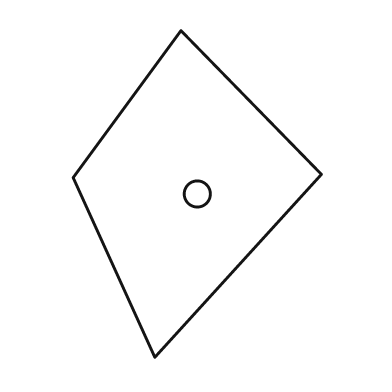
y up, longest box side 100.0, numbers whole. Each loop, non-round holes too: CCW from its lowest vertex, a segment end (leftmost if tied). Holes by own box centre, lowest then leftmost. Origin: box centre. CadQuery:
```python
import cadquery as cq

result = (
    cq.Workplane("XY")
    .moveTo(-13.0, -50.0)
    .lineTo(38.0, 6.0)
    .lineTo(-5.0, 50.0)
    .lineTo(-38.0, 5.0)
    .close()
    .moveTo(0.0, 0.0)
    .circle(4.0)
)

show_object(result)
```